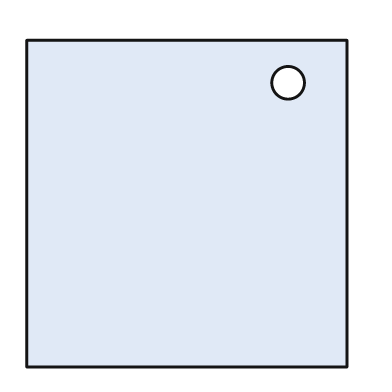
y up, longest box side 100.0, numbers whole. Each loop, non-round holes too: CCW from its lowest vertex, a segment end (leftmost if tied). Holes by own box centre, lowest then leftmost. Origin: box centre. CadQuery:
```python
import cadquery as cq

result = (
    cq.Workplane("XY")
    .moveTo(-49.0, -50.0)
    .lineTo(49.0, -50.0)
    .lineTo(49.0, 50.0)
    .lineTo(-49.0, 50.0)
    .close()
    .moveTo(31.0, 37.0)
    .circle(5.0)
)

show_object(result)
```